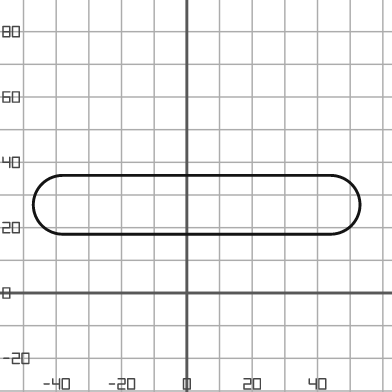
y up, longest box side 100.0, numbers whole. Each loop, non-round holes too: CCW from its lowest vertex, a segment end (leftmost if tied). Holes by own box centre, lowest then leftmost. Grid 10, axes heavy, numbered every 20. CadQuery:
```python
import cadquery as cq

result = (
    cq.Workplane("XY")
    .moveTo(-38.0, 18.0)
    .lineTo(44.0, 18.0)
    .threePointArc((53.0, 27.0), (44.0, 36.0))
    .lineTo(-38.0, 36.0)
    .threePointArc((-47.0, 27.0), (-38.0, 18.0))
    .close()
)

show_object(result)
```